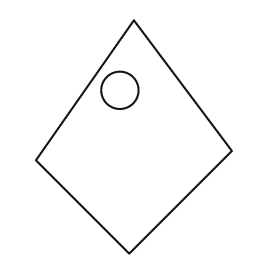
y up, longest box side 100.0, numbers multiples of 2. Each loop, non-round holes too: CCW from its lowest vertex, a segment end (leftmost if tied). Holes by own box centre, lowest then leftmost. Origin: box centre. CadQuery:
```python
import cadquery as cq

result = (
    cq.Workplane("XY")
    .moveTo(-2.0, -50.0)
    .lineTo(42.0, -6.0)
    .lineTo(0.0, 50.0)
    .lineTo(-42.0, -10.0)
    .close()
    .moveTo(-6.0, 20.0)
    .circle(8.0)
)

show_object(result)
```